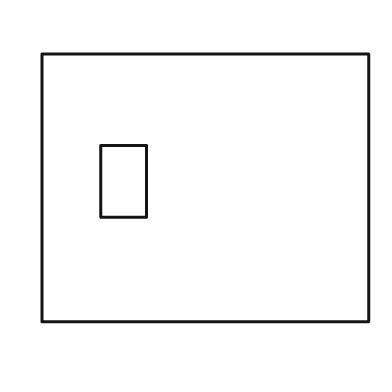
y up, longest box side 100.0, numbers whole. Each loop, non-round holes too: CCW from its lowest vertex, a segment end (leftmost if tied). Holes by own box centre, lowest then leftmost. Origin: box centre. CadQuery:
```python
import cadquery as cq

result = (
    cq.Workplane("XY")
    .moveTo(-50.0, -41.0)
    .lineTo(50.0, -41.0)
    .lineTo(50.0, 41.0)
    .lineTo(-50.0, 41.0)
    .close()
    .moveTo(-32.0, -9.0)
    .lineTo(-18.0, -9.0)
    .lineTo(-18.0, 13.0)
    .lineTo(-32.0, 13.0)
    .close()
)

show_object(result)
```